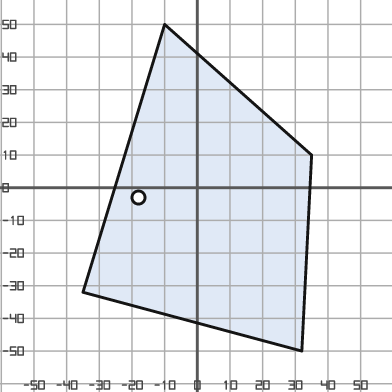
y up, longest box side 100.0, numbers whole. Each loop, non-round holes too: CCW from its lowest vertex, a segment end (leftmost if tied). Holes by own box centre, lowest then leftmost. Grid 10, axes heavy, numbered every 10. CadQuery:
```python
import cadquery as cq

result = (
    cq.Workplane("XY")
    .moveTo(32.0, -50.0)
    .lineTo(35.0, 10.0)
    .lineTo(-10.0, 50.0)
    .lineTo(-35.0, -32.0)
    .close()
    .moveTo(-18.0, -3.0)
    .circle(2.0)
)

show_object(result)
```